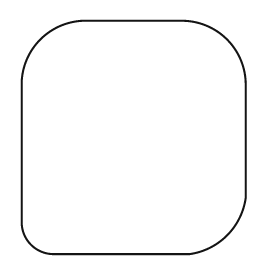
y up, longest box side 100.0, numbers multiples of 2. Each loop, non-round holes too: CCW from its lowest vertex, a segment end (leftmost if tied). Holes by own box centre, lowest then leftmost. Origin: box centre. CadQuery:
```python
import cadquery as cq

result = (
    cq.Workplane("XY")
    .moveTo(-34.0, -50.0)
    .lineTo(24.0, -50.0)
    .threePointArc((40.0, -42.0), (48.0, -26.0))
    .lineTo(48.0, 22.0)
    .threePointArc((40.0, 42.0), (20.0, 50.0))
    .lineTo(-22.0, 50.0)
    .threePointArc((-40.0, 42.0), (-48.0, 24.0))
    .lineTo(-48.0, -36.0)
    .threePointArc((-44.0, -46.0), (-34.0, -50.0))
    .close()
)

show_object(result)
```